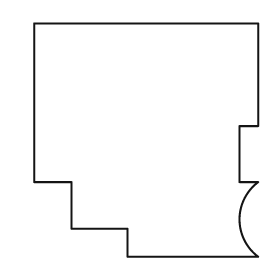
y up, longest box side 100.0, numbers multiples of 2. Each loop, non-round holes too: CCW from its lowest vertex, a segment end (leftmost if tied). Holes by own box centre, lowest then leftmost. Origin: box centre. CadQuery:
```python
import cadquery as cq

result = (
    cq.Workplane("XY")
    .moveTo(-8.0, -50.0)
    .lineTo(48.0, -50.0)
    .threePointArc((40.0, -34.0), (48.0, -18.0))
    .lineTo(40.0, -18.0)
    .lineTo(40.0, 6.0)
    .lineTo(48.0, 6.0)
    .lineTo(48.0, 50.0)
    .lineTo(-48.0, 50.0)
    .lineTo(-48.0, -18.0)
    .lineTo(-32.0, -18.0)
    .lineTo(-32.0, -38.0)
    .lineTo(-8.0, -38.0)
    .close()
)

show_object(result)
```